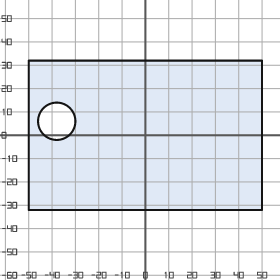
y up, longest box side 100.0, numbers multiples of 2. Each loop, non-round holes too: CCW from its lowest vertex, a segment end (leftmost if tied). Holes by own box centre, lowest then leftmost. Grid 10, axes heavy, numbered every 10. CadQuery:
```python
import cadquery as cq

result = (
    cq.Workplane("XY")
    .moveTo(-50.0, -32.0)
    .lineTo(50.0, -32.0)
    .lineTo(50.0, 32.0)
    .lineTo(-50.0, 32.0)
    .close()
    .moveTo(-38.0, 6.0)
    .circle(8.0)
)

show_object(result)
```